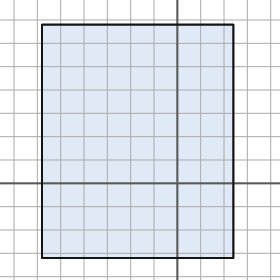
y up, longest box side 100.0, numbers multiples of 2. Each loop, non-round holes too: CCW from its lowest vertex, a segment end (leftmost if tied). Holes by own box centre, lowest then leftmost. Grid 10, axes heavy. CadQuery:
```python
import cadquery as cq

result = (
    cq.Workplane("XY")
    .moveTo(-58.0, -32.0)
    .lineTo(24.0, -32.0)
    .lineTo(24.0, 68.0)
    .lineTo(-58.0, 68.0)
    .close()
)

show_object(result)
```